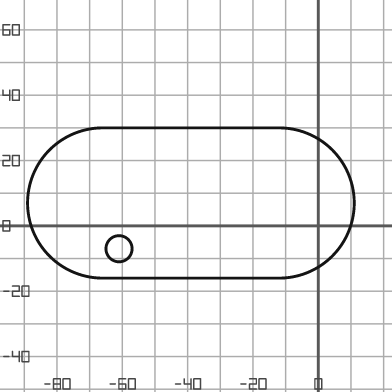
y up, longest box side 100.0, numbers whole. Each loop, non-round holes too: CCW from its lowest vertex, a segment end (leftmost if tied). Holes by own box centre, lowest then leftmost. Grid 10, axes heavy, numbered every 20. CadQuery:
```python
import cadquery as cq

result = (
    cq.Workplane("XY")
    .moveTo(-66.0, -16.0)
    .lineTo(-12.0, -16.0)
    .threePointArc((11.0, 7.0), (-12.0, 30.0))
    .lineTo(-66.0, 30.0)
    .threePointArc((-89.0, 7.0), (-66.0, -16.0))
    .close()
    .moveTo(-61.0, -7.0)
    .circle(4.0)
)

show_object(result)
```